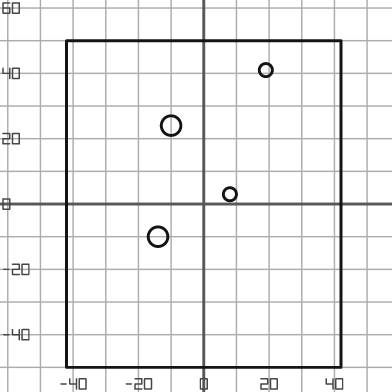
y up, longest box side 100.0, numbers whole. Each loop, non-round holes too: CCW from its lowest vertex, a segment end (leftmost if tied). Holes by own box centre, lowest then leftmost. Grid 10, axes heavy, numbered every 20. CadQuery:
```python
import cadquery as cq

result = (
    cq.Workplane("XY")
    .moveTo(-42.0, -50.0)
    .lineTo(42.0, -50.0)
    .lineTo(42.0, 50.0)
    .lineTo(-42.0, 50.0)
    .close()
    .moveTo(-14.0, -10.0)
    .circle(3.0)
    .moveTo(8.0, 3.0)
    .circle(2.0)
    .moveTo(-10.0, 24.0)
    .circle(3.0)
    .moveTo(19.0, 41.0)
    .circle(2.0)
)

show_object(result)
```